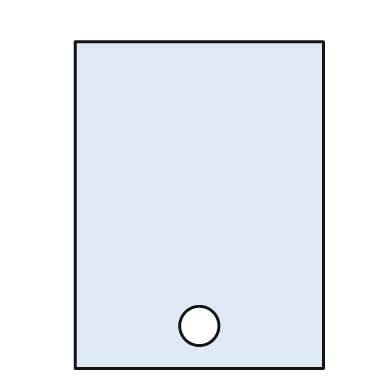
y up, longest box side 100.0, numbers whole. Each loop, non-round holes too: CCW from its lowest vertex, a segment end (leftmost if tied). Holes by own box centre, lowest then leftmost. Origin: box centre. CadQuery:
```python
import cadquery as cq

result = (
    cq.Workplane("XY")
    .moveTo(-38.0, -50.0)
    .lineTo(38.0, -50.0)
    .lineTo(38.0, 50.0)
    .lineTo(-38.0, 50.0)
    .close()
    .moveTo(0.0, -37.0)
    .circle(6.0)
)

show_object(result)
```